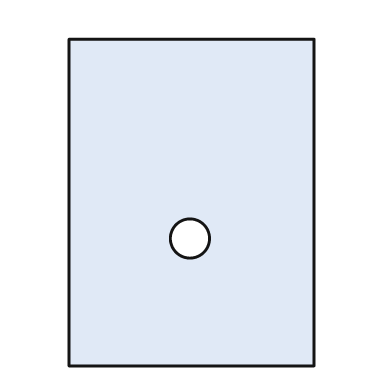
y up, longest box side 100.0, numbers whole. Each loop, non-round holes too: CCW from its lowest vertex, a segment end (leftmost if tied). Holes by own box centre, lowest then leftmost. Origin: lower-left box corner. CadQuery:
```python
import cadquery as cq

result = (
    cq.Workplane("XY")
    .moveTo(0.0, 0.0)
    .lineTo(75.0, 0.0)
    .lineTo(75.0, 100.0)
    .lineTo(0.0, 100.0)
    .close()
    .moveTo(37.0, 39.0)
    .circle(6.0)
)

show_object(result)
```